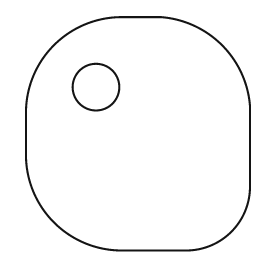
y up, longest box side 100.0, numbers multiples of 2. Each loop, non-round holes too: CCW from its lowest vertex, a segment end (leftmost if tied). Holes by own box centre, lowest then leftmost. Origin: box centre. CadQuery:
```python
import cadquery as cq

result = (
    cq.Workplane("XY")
    .moveTo(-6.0, -50.0)
    .lineTo(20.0, -50.0)
    .threePointArc((40.0, -42.0), (48.0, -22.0))
    .lineTo(48.0, 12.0)
    .threePointArc((36.0, 38.0), (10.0, 50.0))
    .lineTo(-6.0, 50.0)
    .threePointArc((-36.0, 38.0), (-48.0, 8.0))
    .lineTo(-48.0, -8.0)
    .threePointArc((-36.0, -38.0), (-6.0, -50.0))
    .close()
    .moveTo(-18.0, 20.0)
    .circle(10.0)
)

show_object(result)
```